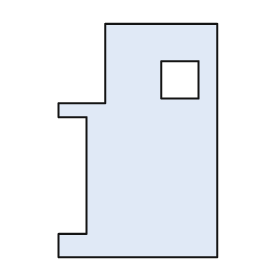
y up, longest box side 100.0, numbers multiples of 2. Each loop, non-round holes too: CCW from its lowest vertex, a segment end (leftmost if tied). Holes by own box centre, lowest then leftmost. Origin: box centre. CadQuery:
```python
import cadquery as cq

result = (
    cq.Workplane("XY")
    .moveTo(-34.0, -50.0)
    .lineTo(34.0, -50.0)
    .lineTo(34.0, 50.0)
    .lineTo(-14.0, 50.0)
    .lineTo(-14.0, 16.0)
    .lineTo(-34.0, 16.0)
    .lineTo(-34.0, 10.0)
    .lineTo(-22.0, 10.0)
    .lineTo(-22.0, -40.0)
    .lineTo(-34.0, -40.0)
    .close()
    .moveTo(10.0, 18.0)
    .lineTo(26.0, 18.0)
    .lineTo(26.0, 34.0)
    .lineTo(10.0, 34.0)
    .close()
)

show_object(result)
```